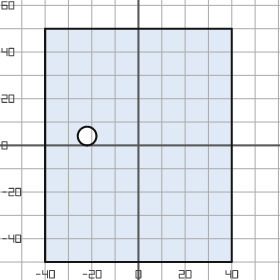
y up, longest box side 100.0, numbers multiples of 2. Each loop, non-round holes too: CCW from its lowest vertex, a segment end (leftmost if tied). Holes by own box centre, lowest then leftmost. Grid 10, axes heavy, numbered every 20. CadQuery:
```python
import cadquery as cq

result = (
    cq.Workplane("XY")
    .moveTo(-40.0, -50.0)
    .lineTo(40.0, -50.0)
    .lineTo(40.0, 50.0)
    .lineTo(-40.0, 50.0)
    .close()
    .moveTo(-22.0, 4.0)
    .circle(4.0)
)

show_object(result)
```